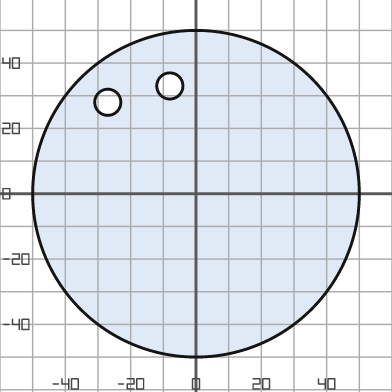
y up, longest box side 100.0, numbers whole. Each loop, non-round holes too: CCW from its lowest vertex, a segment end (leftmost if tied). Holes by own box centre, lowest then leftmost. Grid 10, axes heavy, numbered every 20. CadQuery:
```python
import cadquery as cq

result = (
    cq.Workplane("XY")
    .moveTo(0.0, 0.0)
    .circle(50.0)
    .moveTo(-27.0, 28.0)
    .circle(4.0)
    .moveTo(-8.0, 33.0)
    .circle(4.0)
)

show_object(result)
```